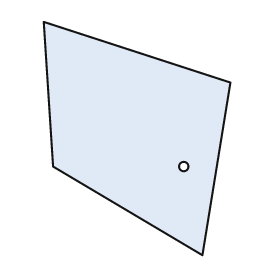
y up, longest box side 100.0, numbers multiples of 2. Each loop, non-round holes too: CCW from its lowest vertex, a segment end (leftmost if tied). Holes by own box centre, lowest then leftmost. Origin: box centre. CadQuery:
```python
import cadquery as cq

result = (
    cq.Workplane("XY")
    .moveTo(28.0, -50.0)
    .lineTo(40.0, 24.0)
    .lineTo(-40.0, 50.0)
    .lineTo(-36.0, -12.0)
    .close()
    .moveTo(20.0, -12.0)
    .circle(2.0)
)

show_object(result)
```